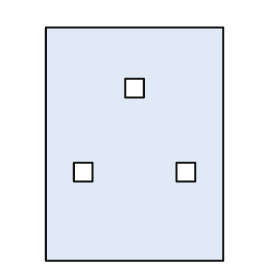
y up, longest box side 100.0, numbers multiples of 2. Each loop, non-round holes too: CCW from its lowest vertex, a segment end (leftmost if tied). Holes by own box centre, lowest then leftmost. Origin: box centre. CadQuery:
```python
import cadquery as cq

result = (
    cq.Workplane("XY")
    .moveTo(-38.0, -50.0)
    .lineTo(38.0, -50.0)
    .lineTo(38.0, 50.0)
    .lineTo(-38.0, 50.0)
    .close()
    .moveTo(-26.0, -16.0)
    .lineTo(-18.0, -16.0)
    .lineTo(-18.0, -8.0)
    .lineTo(-26.0, -8.0)
    .close()
    .moveTo(18.0, -16.0)
    .lineTo(26.0, -16.0)
    .lineTo(26.0, -8.0)
    .lineTo(18.0, -8.0)
    .close()
    .moveTo(-4.0, 20.0)
    .lineTo(4.0, 20.0)
    .lineTo(4.0, 28.0)
    .lineTo(-4.0, 28.0)
    .close()
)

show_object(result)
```